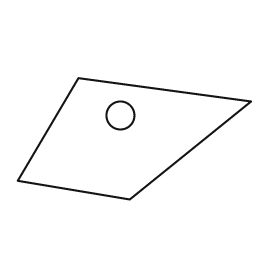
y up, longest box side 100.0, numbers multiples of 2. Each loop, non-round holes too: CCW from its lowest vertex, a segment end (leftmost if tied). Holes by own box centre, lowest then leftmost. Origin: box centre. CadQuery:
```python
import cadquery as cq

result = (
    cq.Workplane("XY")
    .moveTo(-2.0, -26.0)
    .lineTo(50.0, 16.0)
    .lineTo(-24.0, 26.0)
    .lineTo(-50.0, -18.0)
    .close()
    .moveTo(-6.0, 10.0)
    .circle(6.0)
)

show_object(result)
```